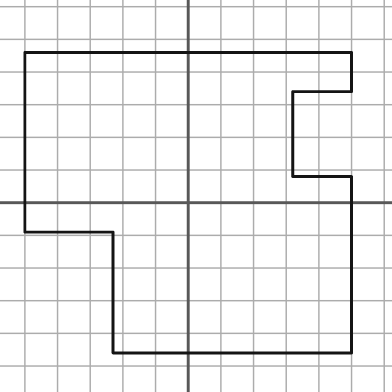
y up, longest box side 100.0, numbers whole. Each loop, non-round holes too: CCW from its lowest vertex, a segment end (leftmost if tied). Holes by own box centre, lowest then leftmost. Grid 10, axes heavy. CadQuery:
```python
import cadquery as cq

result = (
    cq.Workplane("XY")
    .moveTo(-23.0, -46.0)
    .lineTo(50.0, -46.0)
    .lineTo(50.0, 8.0)
    .lineTo(32.0, 8.0)
    .lineTo(32.0, 34.0)
    .lineTo(50.0, 34.0)
    .lineTo(50.0, 46.0)
    .lineTo(-50.0, 46.0)
    .lineTo(-50.0, -9.0)
    .lineTo(-23.0, -9.0)
    .close()
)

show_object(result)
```